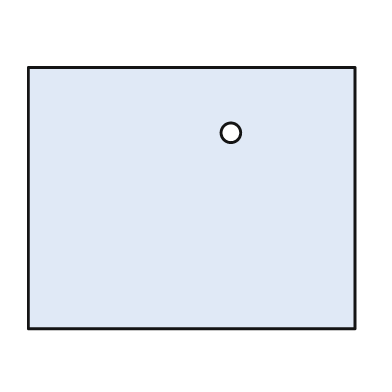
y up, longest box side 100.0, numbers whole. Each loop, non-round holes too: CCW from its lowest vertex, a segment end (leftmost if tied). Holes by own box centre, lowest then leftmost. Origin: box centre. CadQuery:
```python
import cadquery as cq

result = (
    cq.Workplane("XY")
    .moveTo(-50.0, -40.0)
    .lineTo(50.0, -40.0)
    .lineTo(50.0, 40.0)
    .lineTo(-50.0, 40.0)
    .close()
    .moveTo(12.0, 20.0)
    .circle(3.0)
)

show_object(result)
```